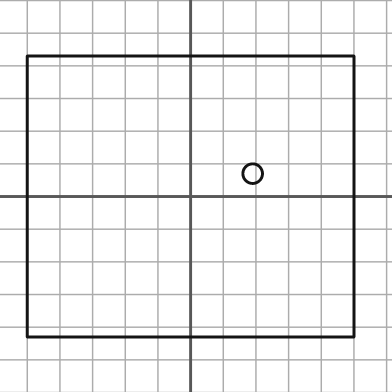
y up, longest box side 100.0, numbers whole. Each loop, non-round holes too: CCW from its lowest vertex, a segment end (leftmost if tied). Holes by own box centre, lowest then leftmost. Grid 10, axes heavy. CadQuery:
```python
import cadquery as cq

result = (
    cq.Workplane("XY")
    .moveTo(-50.0, -43.0)
    .lineTo(50.0, -43.0)
    .lineTo(50.0, 43.0)
    .lineTo(-50.0, 43.0)
    .close()
    .moveTo(19.0, 7.0)
    .circle(3.0)
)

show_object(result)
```